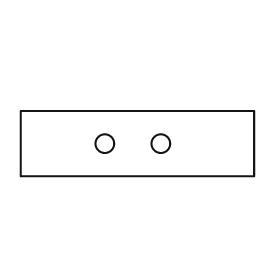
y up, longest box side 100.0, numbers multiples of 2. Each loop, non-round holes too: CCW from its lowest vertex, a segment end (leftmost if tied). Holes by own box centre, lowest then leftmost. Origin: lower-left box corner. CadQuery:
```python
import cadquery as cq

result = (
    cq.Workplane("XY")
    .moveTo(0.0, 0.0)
    .lineTo(100.0, 0.0)
    .lineTo(100.0, 28.0)
    .lineTo(0.0, 28.0)
    .close()
    .moveTo(36.0, 14.0)
    .circle(4.0)
    .moveTo(60.0, 14.0)
    .circle(4.0)
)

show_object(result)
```